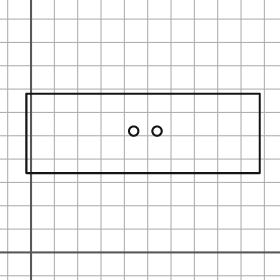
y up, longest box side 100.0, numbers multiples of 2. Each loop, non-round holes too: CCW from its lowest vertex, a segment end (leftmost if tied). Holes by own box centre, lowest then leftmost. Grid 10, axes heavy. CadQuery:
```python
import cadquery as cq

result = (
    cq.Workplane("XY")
    .moveTo(-2.0, 34.0)
    .lineTo(98.0, 34.0)
    .lineTo(98.0, 68.0)
    .lineTo(-2.0, 68.0)
    .close()
    .moveTo(44.0, 52.0)
    .circle(2.0)
    .moveTo(54.0, 52.0)
    .circle(2.0)
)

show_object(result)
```